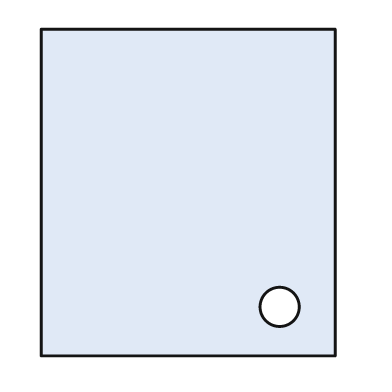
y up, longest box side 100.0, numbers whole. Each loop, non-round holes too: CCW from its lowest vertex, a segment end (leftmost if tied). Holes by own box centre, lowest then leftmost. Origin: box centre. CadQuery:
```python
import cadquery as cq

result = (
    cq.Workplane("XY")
    .moveTo(-45.0, -50.0)
    .lineTo(45.0, -50.0)
    .lineTo(45.0, 50.0)
    .lineTo(-45.0, 50.0)
    .close()
    .moveTo(28.0, -35.0)
    .circle(6.0)
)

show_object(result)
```